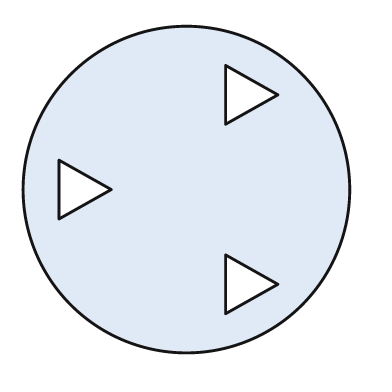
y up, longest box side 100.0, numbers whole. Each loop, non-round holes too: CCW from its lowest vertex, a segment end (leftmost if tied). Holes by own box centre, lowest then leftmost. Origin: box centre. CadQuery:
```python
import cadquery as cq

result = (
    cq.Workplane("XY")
    .moveTo(0.0, 0.0)
    .circle(50.0)
    .moveTo(12.0, -38.0)
    .lineTo(28.0, -29.0)
    .lineTo(12.0, -20.0)
    .close()
    .moveTo(-39.0, -9.0)
    .lineTo(-23.0, 0.0)
    .lineTo(-39.0, 9.0)
    .close()
    .moveTo(12.0, 20.0)
    .lineTo(28.0, 29.0)
    .lineTo(12.0, 38.0)
    .close()
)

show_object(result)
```